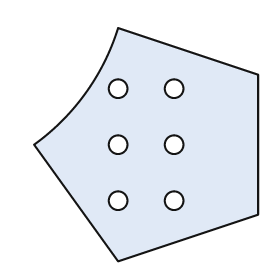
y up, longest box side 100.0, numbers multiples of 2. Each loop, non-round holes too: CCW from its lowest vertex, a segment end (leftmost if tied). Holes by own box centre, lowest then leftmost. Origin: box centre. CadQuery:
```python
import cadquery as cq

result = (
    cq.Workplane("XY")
    .moveTo(-12.0, -50.0)
    .lineTo(48.0, -30.0)
    .lineTo(48.0, 30.0)
    .lineTo(-12.0, 50.0)
    .threePointArc((-26.0, 22.0), (-48.0, 0.0))
    .close()
    .moveTo(-12.0, -24.0)
    .circle(4.0)
    .moveTo(12.0, -24.0)
    .circle(4.0)
    .moveTo(-12.0, 0.0)
    .circle(4.0)
    .moveTo(12.0, 0.0)
    .circle(4.0)
    .moveTo(-12.0, 24.0)
    .circle(4.0)
    .moveTo(12.0, 24.0)
    .circle(4.0)
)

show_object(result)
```